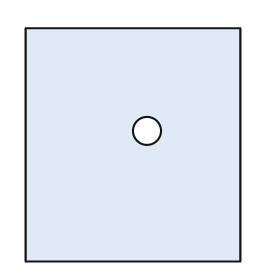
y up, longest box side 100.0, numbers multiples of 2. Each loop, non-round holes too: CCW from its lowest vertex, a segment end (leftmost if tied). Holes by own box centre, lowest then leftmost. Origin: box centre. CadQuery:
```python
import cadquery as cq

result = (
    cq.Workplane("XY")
    .moveTo(-46.0, -50.0)
    .lineTo(46.0, -50.0)
    .lineTo(46.0, 50.0)
    .lineTo(-46.0, 50.0)
    .close()
    .moveTo(6.0, 6.0)
    .circle(6.0)
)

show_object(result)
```